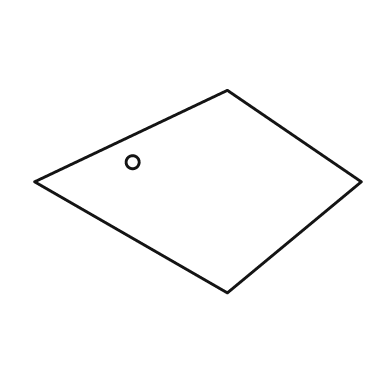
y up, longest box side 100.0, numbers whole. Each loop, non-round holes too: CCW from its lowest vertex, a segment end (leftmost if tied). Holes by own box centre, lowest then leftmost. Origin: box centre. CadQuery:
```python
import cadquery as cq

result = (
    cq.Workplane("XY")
    .moveTo(9.0, -31.0)
    .lineTo(50.0, 3.0)
    .lineTo(9.0, 31.0)
    .lineTo(-50.0, 3.0)
    .close()
    .moveTo(-20.0, 9.0)
    .circle(2.0)
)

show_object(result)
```